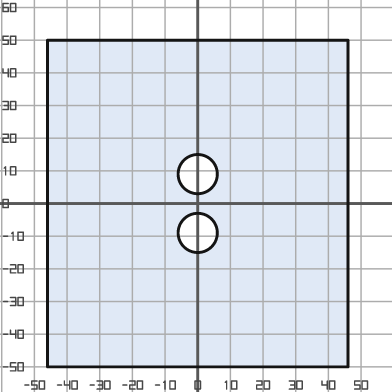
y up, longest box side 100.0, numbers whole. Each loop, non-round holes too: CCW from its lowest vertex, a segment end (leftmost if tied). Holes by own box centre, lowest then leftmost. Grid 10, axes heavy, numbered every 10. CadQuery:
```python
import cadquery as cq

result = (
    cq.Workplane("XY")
    .moveTo(-46.0, -50.0)
    .lineTo(46.0, -50.0)
    .lineTo(46.0, 50.0)
    .lineTo(-46.0, 50.0)
    .close()
    .moveTo(0.0, -9.0)
    .circle(6.0)
    .moveTo(0.0, 9.0)
    .circle(6.0)
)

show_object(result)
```